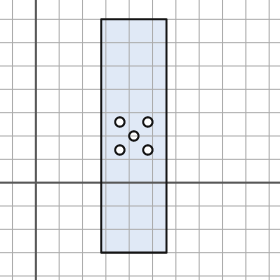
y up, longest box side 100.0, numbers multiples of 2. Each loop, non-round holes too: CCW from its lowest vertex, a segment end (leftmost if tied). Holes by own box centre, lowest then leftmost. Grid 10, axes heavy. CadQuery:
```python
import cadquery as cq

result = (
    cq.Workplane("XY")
    .moveTo(28.0, -30.0)
    .lineTo(56.0, -30.0)
    .lineTo(56.0, 70.0)
    .lineTo(28.0, 70.0)
    .close()
    .moveTo(36.0, 14.0)
    .circle(2.0)
    .moveTo(48.0, 14.0)
    .circle(2.0)
    .moveTo(42.0, 20.0)
    .circle(2.0)
    .moveTo(36.0, 26.0)
    .circle(2.0)
    .moveTo(48.0, 26.0)
    .circle(2.0)
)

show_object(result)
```